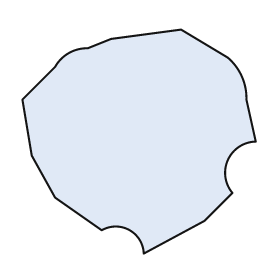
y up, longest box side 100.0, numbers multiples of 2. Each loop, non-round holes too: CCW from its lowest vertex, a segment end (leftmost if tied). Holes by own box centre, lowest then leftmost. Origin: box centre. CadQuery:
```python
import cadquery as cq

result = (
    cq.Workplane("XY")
    .moveTo(2.0, -48.0)
    .lineTo(28.0, -34.0)
    .lineTo(40.0, -22.0)
    .threePointArc((38.0, -8.0), (50.0, 0.0))
    .lineTo(46.0, 18.0)
    .threePointArc((44.0, 28.0), (38.0, 36.0))
    .lineTo(18.0, 48.0)
    .lineTo(-12.0, 44.0)
    .lineTo(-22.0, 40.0)
    .threePointArc((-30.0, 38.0), (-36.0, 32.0))
    .lineTo(-50.0, 18.0)
    .lineTo(-46.0, -6.0)
    .lineTo(-36.0, -24.0)
    .lineTo(-16.0, -38.0)
    .threePointArc((-4.0, -38.0), (2.0, -48.0))
    .close()
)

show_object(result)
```